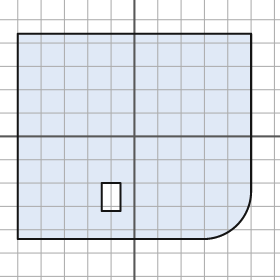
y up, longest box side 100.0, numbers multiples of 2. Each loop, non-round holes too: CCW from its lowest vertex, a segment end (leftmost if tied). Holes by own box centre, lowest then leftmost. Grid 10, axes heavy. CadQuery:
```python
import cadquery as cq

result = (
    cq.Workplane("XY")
    .moveTo(-50.0, -44.0)
    .lineTo(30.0, -44.0)
    .threePointArc((44.0, -38.0), (50.0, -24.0))
    .lineTo(50.0, 44.0)
    .lineTo(-50.0, 44.0)
    .close()
    .moveTo(-14.0, -32.0)
    .lineTo(-6.0, -32.0)
    .lineTo(-6.0, -20.0)
    .lineTo(-14.0, -20.0)
    .close()
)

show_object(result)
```